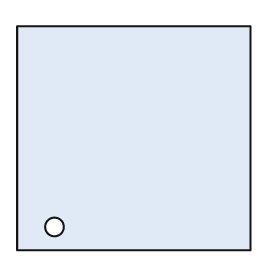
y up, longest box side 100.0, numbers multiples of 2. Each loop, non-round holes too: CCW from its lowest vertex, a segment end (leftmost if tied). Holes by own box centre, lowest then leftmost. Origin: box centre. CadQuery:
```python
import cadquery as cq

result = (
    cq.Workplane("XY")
    .moveTo(-50.0, -48.0)
    .lineTo(50.0, -48.0)
    .lineTo(50.0, 48.0)
    .lineTo(-50.0, 48.0)
    .close()
    .moveTo(-34.0, -38.0)
    .circle(4.0)
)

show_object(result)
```